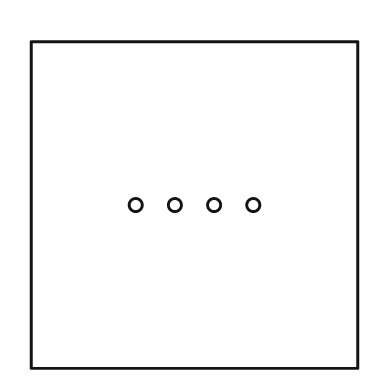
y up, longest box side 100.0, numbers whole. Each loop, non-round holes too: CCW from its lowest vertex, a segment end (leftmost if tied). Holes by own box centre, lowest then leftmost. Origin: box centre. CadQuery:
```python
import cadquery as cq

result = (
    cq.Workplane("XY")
    .moveTo(-50.0, -50.0)
    .lineTo(50.0, -50.0)
    .lineTo(50.0, 50.0)
    .lineTo(-50.0, 50.0)
    .close()
    .moveTo(-18.0, 0.0)
    .circle(2.0)
    .moveTo(-6.0, 0.0)
    .circle(2.0)
    .moveTo(6.0, 0.0)
    .circle(2.0)
    .moveTo(18.0, 0.0)
    .circle(2.0)
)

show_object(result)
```